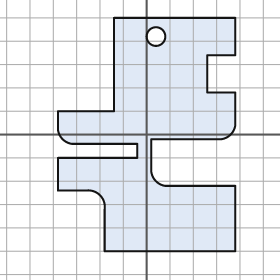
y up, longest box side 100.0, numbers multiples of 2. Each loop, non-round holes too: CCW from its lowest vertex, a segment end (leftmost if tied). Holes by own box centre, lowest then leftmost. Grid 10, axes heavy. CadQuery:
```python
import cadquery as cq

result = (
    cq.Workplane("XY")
    .moveTo(-18.0, -50.0)
    .lineTo(38.0, -50.0)
    .lineTo(38.0, -22.0)
    .lineTo(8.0, -22.0)
    .threePointArc((4.0, -20.0), (2.0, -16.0))
    .lineTo(2.0, -2.0)
    .lineTo(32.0, -2.0)
    .threePointArc((36.0, 0.0), (38.0, 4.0))
    .lineTo(38.0, 18.0)
    .lineTo(26.0, 18.0)
    .lineTo(26.0, 34.0)
    .lineTo(38.0, 34.0)
    .lineTo(38.0, 50.0)
    .lineTo(-14.0, 50.0)
    .lineTo(-14.0, 10.0)
    .lineTo(-38.0, 10.0)
    .lineTo(-38.0, 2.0)
    .threePointArc((-36.0, -2.0), (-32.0, -4.0))
    .lineTo(-4.0, -4.0)
    .lineTo(-4.0, -10.0)
    .lineTo(-38.0, -10.0)
    .lineTo(-38.0, -24.0)
    .lineTo(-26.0, -24.0)
    .threePointArc((-20.0, -26.0), (-18.0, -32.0))
    .close()
    .moveTo(4.0, 42.0)
    .circle(4.0)
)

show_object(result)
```